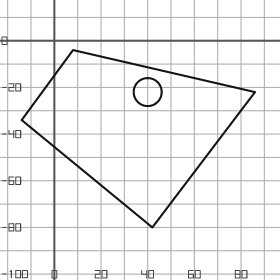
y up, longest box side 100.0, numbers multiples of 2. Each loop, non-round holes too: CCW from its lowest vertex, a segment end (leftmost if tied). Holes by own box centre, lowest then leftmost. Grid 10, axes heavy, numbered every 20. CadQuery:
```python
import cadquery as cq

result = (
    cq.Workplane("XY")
    .moveTo(42.0, -80.0)
    .lineTo(86.0, -22.0)
    .lineTo(8.0, -4.0)
    .lineTo(-14.0, -34.0)
    .close()
    .moveTo(40.0, -22.0)
    .circle(6.0)
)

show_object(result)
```